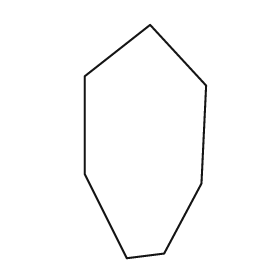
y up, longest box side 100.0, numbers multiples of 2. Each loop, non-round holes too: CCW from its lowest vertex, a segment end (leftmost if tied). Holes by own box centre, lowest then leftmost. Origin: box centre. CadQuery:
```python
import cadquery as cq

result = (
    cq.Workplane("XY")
    .moveTo(-8.0, -50.0)
    .lineTo(8.0, -48.0)
    .lineTo(24.0, -18.0)
    .lineTo(26.0, 24.0)
    .lineTo(2.0, 50.0)
    .lineTo(-26.0, 28.0)
    .lineTo(-26.0, -14.0)
    .close()
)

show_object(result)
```